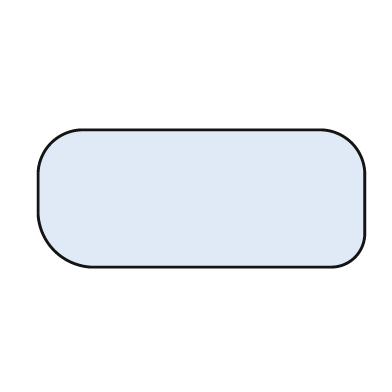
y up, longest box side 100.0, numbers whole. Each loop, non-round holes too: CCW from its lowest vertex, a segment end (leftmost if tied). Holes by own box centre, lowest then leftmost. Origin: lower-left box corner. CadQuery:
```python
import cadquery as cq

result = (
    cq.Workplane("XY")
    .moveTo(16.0, 0.0)
    .lineTo(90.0, 0.0)
    .threePointArc((97.0, 3.0), (100.0, 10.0))
    .lineTo(100.0, 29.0)
    .threePointArc((96.0, 38.0), (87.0, 42.0))
    .lineTo(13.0, 42.0)
    .threePointArc((4.0, 38.0), (0.0, 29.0))
    .lineTo(0.0, 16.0)
    .threePointArc((5.0, 5.0), (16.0, 0.0))
    .close()
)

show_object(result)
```